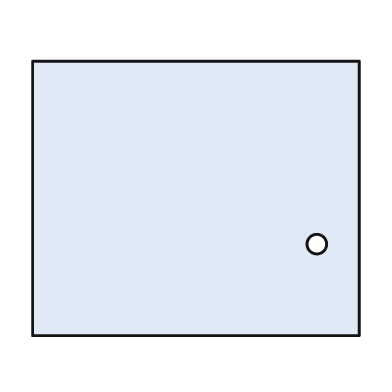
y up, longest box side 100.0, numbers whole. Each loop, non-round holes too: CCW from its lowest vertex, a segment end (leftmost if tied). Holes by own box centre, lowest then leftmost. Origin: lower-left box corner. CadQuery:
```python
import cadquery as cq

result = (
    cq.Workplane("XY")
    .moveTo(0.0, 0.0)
    .lineTo(100.0, 0.0)
    .lineTo(100.0, 84.0)
    .lineTo(0.0, 84.0)
    .close()
    .moveTo(87.0, 28.0)
    .circle(3.0)
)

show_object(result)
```